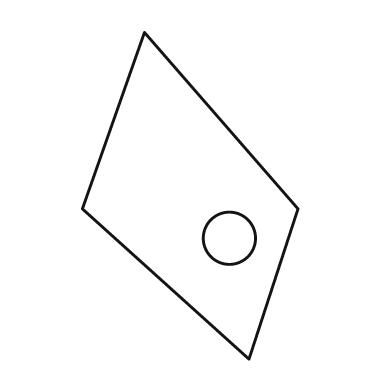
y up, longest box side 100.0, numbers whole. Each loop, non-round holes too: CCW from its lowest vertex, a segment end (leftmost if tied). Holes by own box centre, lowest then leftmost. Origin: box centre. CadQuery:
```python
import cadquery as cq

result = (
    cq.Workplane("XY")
    .moveTo(18.0, -50.0)
    .lineTo(33.0, -4.0)
    .lineTo(-14.0, 50.0)
    .lineTo(-33.0, -4.0)
    .close()
    .moveTo(12.0, -13.0)
    .circle(8.0)
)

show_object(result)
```